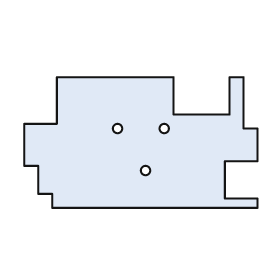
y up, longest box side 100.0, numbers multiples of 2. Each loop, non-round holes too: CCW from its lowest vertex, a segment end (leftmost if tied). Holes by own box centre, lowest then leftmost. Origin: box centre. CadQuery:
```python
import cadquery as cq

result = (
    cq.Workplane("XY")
    .moveTo(-38.0, -28.0)
    .lineTo(50.0, -28.0)
    .lineTo(50.0, -24.0)
    .lineTo(36.0, -24.0)
    .lineTo(36.0, -8.0)
    .lineTo(50.0, -8.0)
    .lineTo(50.0, 6.0)
    .lineTo(44.0, 6.0)
    .lineTo(44.0, 28.0)
    .lineTo(38.0, 28.0)
    .lineTo(38.0, 12.0)
    .lineTo(14.0, 12.0)
    .lineTo(14.0, 28.0)
    .lineTo(-36.0, 28.0)
    .lineTo(-36.0, 8.0)
    .lineTo(-50.0, 8.0)
    .lineTo(-50.0, -10.0)
    .lineTo(-44.0, -10.0)
    .lineTo(-44.0, -22.0)
    .lineTo(-38.0, -22.0)
    .close()
    .moveTo(2.0, -12.0)
    .circle(2.0)
    .moveTo(-10.0, 6.0)
    .circle(2.0)
    .moveTo(10.0, 6.0)
    .circle(2.0)
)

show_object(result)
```